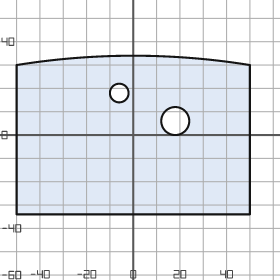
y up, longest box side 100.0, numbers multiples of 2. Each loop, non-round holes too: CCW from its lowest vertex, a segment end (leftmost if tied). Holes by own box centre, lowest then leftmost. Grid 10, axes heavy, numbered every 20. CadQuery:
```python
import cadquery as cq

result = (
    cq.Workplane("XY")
    .moveTo(-50.0, -34.0)
    .lineTo(50.0, -34.0)
    .lineTo(50.0, 30.0)
    .threePointArc((0.0, 34.0), (-50.0, 30.0))
    .close()
    .moveTo(18.0, 6.0)
    .circle(6.0)
    .moveTo(-6.0, 18.0)
    .circle(4.0)
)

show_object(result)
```